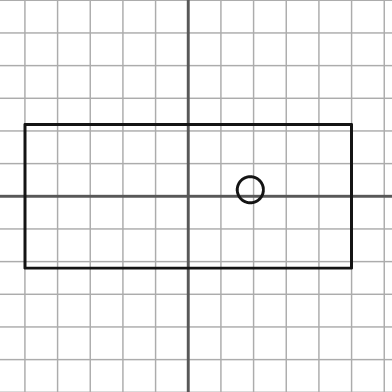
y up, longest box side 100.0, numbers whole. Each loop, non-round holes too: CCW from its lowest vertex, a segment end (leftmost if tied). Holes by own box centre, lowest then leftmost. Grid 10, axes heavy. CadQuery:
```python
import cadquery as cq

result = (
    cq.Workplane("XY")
    .moveTo(-50.0, -22.0)
    .lineTo(50.0, -22.0)
    .lineTo(50.0, 22.0)
    .lineTo(-50.0, 22.0)
    .close()
    .moveTo(19.0, 2.0)
    .circle(4.0)
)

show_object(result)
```